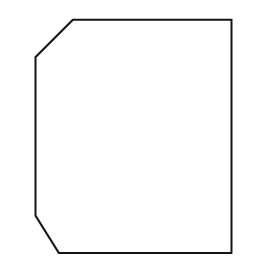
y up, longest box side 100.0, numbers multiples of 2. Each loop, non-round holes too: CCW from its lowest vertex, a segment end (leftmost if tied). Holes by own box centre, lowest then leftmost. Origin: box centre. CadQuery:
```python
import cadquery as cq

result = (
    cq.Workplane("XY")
    .moveTo(-32.0, -50.0)
    .lineTo(42.0, -50.0)
    .lineTo(42.0, 50.0)
    .lineTo(-26.0, 50.0)
    .lineTo(-42.0, 34.0)
    .lineTo(-42.0, -34.0)
    .close()
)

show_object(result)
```